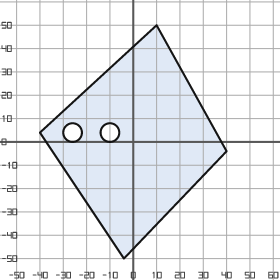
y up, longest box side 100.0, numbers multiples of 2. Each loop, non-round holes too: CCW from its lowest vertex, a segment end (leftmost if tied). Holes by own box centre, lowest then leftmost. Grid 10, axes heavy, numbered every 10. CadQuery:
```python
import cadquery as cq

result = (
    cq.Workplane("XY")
    .moveTo(-4.0, -50.0)
    .lineTo(40.0, -4.0)
    .lineTo(10.0, 50.0)
    .lineTo(-40.0, 4.0)
    .close()
    .moveTo(-26.0, 4.0)
    .circle(4.0)
    .moveTo(-10.0, 4.0)
    .circle(4.0)
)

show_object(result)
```